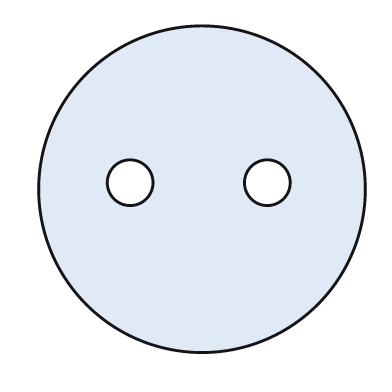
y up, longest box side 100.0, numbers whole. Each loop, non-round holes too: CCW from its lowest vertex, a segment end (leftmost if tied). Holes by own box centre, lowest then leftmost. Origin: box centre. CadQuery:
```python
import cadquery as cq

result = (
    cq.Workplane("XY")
    .moveTo(0.0, 0.0)
    .circle(50.0)
    .moveTo(-22.0, 2.0)
    .circle(7.0)
    .moveTo(20.0, 2.0)
    .circle(7.0)
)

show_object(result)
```